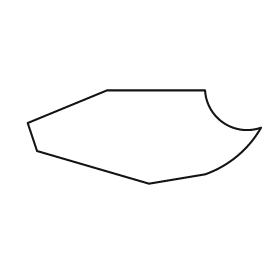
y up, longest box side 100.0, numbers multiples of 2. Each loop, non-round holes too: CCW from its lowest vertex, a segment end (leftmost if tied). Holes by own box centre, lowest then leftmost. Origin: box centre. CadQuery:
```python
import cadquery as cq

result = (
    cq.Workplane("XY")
    .moveTo(2.0, -20.0)
    .lineTo(26.0, -16.0)
    .threePointArc((40.0, -8.0), (50.0, 4.0))
    .threePointArc((34.0, 6.0), (26.0, 20.0))
    .lineTo(-16.0, 20.0)
    .lineTo(-50.0, 6.0)
    .lineTo(-46.0, -6.0)
    .close()
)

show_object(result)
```